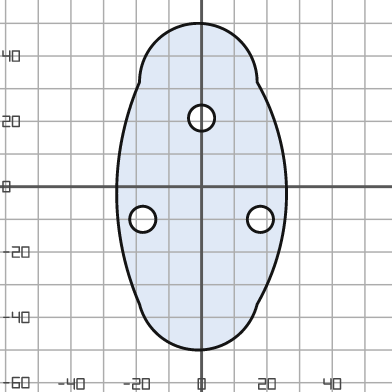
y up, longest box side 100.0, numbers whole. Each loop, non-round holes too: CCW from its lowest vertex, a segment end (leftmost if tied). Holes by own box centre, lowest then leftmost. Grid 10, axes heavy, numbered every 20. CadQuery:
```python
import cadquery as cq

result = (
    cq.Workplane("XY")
    .moveTo(-19.0, -36.0)
    .threePointArc((-1.0, -50.0), (17.0, -36.0))
    .threePointArc((26.0, -2.0), (17.0, 32.0))
    .threePointArc((-1.0, 50.0), (-19.0, 32.0))
    .threePointArc((-26.0, -2.0), (-19.0, -36.0))
    .close()
    .moveTo(-18.0, -10.0)
    .circle(4.0)
    .moveTo(18.0, -10.0)
    .circle(4.0)
    .moveTo(0.0, 21.0)
    .circle(4.0)
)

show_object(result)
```